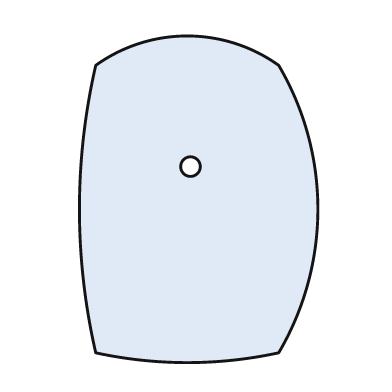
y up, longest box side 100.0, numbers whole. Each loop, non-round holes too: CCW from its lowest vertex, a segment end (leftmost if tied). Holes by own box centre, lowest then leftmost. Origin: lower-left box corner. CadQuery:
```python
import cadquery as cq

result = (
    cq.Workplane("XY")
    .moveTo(5.0, 3.0)
    .threePointArc((33.0, 0.0), (61.0, 3.0))
    .threePointArc((73.0, 47.0), (61.0, 91.0))
    .threePointArc((33.0, 100.0), (5.0, 91.0))
    .threePointArc((0.0, 47.0), (5.0, 3.0))
    .close()
    .moveTo(34.0, 60.0)
    .circle(3.0)
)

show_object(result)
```